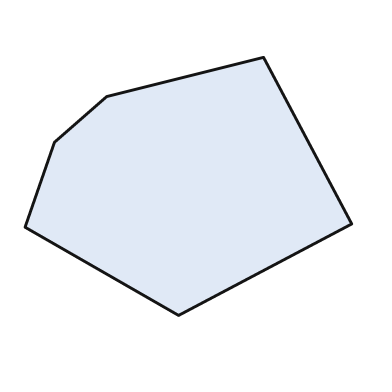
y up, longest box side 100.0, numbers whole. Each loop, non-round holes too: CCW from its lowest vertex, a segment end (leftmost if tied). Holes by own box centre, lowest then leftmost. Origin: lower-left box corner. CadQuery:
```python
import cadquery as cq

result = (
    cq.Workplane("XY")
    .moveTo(47.0, 0.0)
    .lineTo(100.0, 28.0)
    .lineTo(73.0, 79.0)
    .lineTo(25.0, 67.0)
    .lineTo(9.0, 53.0)
    .lineTo(0.0, 27.0)
    .close()
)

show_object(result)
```